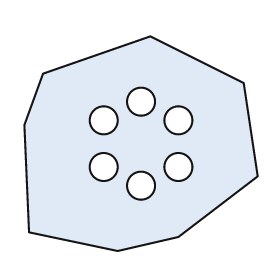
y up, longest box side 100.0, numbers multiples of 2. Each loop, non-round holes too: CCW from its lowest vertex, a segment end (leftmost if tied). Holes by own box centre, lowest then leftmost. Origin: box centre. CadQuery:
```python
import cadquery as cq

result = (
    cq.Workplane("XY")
    .moveTo(-10.0, -46.0)
    .lineTo(16.0, -40.0)
    .lineTo(50.0, -14.0)
    .lineTo(44.0, 26.0)
    .lineTo(4.0, 46.0)
    .lineTo(-42.0, 30.0)
    .lineTo(-50.0, 8.0)
    .lineTo(-48.0, -38.0)
    .close()
    .moveTo(0.0, -18.0)
    .circle(6.0)
    .moveTo(-16.0, -10.0)
    .circle(6.0)
    .moveTo(16.0, -10.0)
    .circle(6.0)
    .moveTo(-16.0, 10.0)
    .circle(6.0)
    .moveTo(16.0, 10.0)
    .circle(6.0)
    .moveTo(0.0, 18.0)
    .circle(6.0)
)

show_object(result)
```